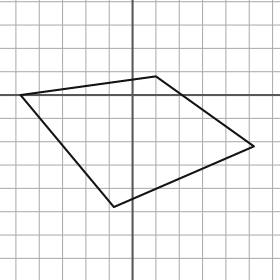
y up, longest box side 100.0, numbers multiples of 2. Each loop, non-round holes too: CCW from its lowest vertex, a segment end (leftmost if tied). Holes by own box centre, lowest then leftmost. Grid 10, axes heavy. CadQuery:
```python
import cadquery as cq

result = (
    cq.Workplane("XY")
    .moveTo(-8.0, -48.0)
    .lineTo(52.0, -22.0)
    .lineTo(10.0, 8.0)
    .lineTo(-48.0, 0.0)
    .close()
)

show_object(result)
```